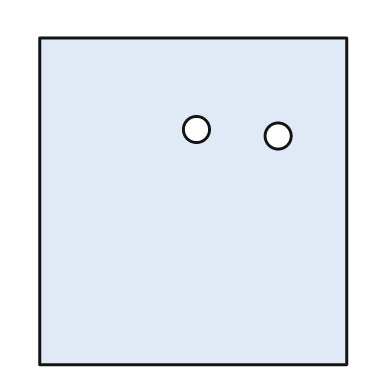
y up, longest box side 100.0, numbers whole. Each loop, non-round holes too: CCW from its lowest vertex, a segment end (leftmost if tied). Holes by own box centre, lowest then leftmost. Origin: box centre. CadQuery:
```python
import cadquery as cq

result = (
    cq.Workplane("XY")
    .moveTo(-47.0, -50.0)
    .lineTo(47.0, -50.0)
    .lineTo(47.0, 50.0)
    .lineTo(-47.0, 50.0)
    .close()
    .moveTo(26.0, 20.0)
    .circle(4.0)
    .moveTo(1.0, 22.0)
    .circle(4.0)
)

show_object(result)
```